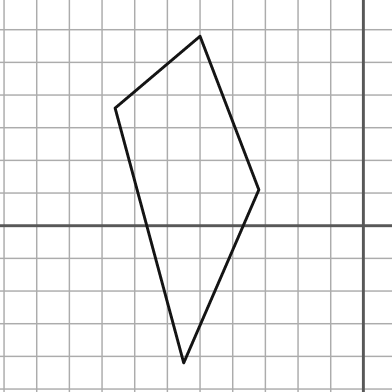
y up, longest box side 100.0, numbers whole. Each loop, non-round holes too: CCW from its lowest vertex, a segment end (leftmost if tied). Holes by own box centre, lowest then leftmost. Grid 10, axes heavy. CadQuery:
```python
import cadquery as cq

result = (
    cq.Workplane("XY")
    .moveTo(-55.0, -42.0)
    .lineTo(-32.0, 11.0)
    .lineTo(-50.0, 58.0)
    .lineTo(-76.0, 36.0)
    .close()
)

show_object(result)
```